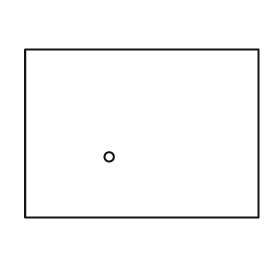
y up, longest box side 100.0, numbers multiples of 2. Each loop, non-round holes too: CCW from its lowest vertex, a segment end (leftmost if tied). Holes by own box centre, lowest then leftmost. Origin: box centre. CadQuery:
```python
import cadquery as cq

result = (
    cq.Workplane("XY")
    .moveTo(-50.0, -36.0)
    .lineTo(50.0, -36.0)
    .lineTo(50.0, 36.0)
    .lineTo(-50.0, 36.0)
    .close()
    .moveTo(-14.0, -10.0)
    .circle(2.0)
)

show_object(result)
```